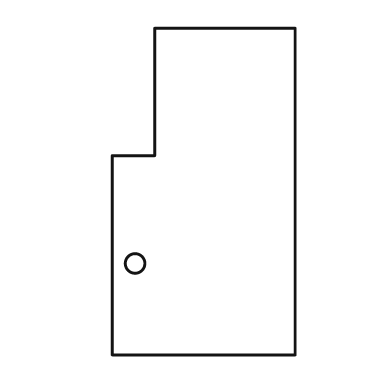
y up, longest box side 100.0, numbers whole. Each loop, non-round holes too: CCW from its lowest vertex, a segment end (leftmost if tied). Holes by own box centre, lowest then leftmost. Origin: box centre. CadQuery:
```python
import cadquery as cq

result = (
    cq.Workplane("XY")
    .moveTo(-28.0, -50.0)
    .lineTo(28.0, -50.0)
    .lineTo(28.0, 50.0)
    .lineTo(-15.0, 50.0)
    .lineTo(-15.0, 11.0)
    .lineTo(-28.0, 11.0)
    .close()
    .moveTo(-21.0, -22.0)
    .circle(3.0)
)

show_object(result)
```